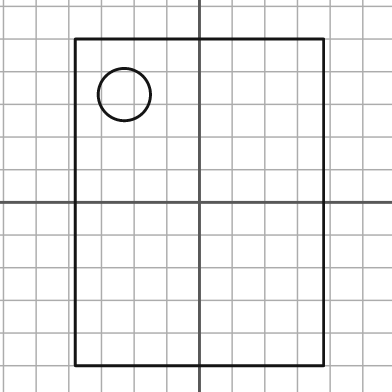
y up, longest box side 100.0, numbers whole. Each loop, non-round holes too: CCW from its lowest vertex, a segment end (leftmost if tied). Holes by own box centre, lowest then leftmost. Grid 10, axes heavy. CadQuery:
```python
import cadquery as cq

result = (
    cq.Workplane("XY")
    .moveTo(-38.0, -50.0)
    .lineTo(38.0, -50.0)
    .lineTo(38.0, 50.0)
    .lineTo(-38.0, 50.0)
    .close()
    .moveTo(-23.0, 33.0)
    .circle(8.0)
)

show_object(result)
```